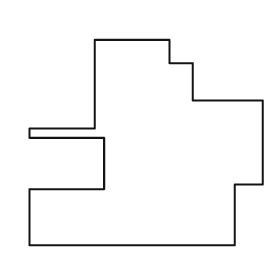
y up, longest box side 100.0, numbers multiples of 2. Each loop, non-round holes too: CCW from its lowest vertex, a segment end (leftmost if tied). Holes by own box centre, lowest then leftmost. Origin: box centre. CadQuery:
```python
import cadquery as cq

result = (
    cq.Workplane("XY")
    .moveTo(-50.0, -44.0)
    .lineTo(38.0, -44.0)
    .lineTo(38.0, -18.0)
    .lineTo(50.0, -18.0)
    .lineTo(50.0, 18.0)
    .lineTo(20.0, 18.0)
    .lineTo(20.0, 34.0)
    .lineTo(10.0, 34.0)
    .lineTo(10.0, 44.0)
    .lineTo(-22.0, 44.0)
    .lineTo(-22.0, 6.0)
    .lineTo(-50.0, 6.0)
    .lineTo(-50.0, 2.0)
    .lineTo(-18.0, 2.0)
    .lineTo(-18.0, -20.0)
    .lineTo(-50.0, -20.0)
    .close()
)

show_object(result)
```